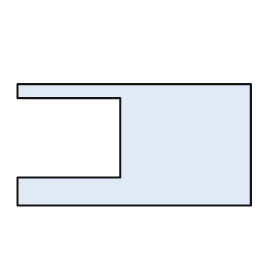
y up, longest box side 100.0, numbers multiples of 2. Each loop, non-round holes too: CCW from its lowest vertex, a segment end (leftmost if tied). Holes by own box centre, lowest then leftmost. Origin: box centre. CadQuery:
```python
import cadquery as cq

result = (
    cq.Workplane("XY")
    .moveTo(-50.0, -26.0)
    .lineTo(50.0, -26.0)
    .lineTo(50.0, 26.0)
    .lineTo(-50.0, 26.0)
    .lineTo(-50.0, 20.0)
    .lineTo(-6.0, 20.0)
    .lineTo(-6.0, -14.0)
    .lineTo(-50.0, -14.0)
    .close()
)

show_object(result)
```